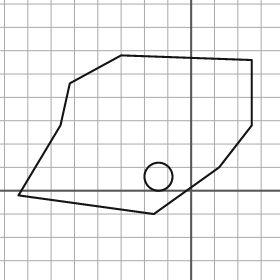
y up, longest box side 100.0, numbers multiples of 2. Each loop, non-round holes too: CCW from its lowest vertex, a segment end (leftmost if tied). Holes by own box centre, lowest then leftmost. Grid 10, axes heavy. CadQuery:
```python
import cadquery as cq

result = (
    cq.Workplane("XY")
    .moveTo(-16.0, -10.0)
    .lineTo(12.0, 10.0)
    .lineTo(26.0, 28.0)
    .lineTo(26.0, 56.0)
    .lineTo(-30.0, 58.0)
    .lineTo(-52.0, 46.0)
    .lineTo(-56.0, 28.0)
    .lineTo(-74.0, -2.0)
    .close()
    .moveTo(-14.0, 6.0)
    .circle(6.0)
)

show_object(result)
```